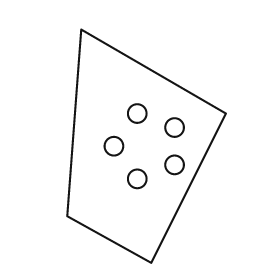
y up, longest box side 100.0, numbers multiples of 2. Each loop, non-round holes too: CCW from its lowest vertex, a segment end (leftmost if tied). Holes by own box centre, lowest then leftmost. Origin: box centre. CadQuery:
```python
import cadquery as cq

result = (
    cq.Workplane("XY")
    .moveTo(2.0, -50.0)
    .lineTo(34.0, 14.0)
    .lineTo(-28.0, 50.0)
    .lineTo(-34.0, -30.0)
    .close()
    .moveTo(-4.0, -14.0)
    .circle(4.0)
    .moveTo(12.0, -8.0)
    .circle(4.0)
    .moveTo(-14.0, 0.0)
    .circle(4.0)
    .moveTo(12.0, 8.0)
    .circle(4.0)
    .moveTo(-4.0, 14.0)
    .circle(4.0)
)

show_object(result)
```